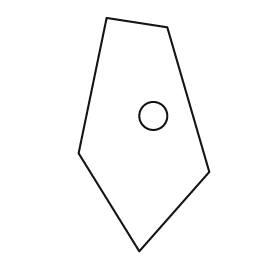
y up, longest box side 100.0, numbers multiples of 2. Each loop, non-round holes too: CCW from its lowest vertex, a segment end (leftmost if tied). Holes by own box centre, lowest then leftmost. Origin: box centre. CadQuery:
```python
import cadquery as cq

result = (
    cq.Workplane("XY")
    .moveTo(-2.0, -50.0)
    .lineTo(28.0, -16.0)
    .lineTo(10.0, 46.0)
    .lineTo(-16.0, 50.0)
    .lineTo(-28.0, -8.0)
    .close()
    .moveTo(4.0, 8.0)
    .circle(6.0)
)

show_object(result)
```